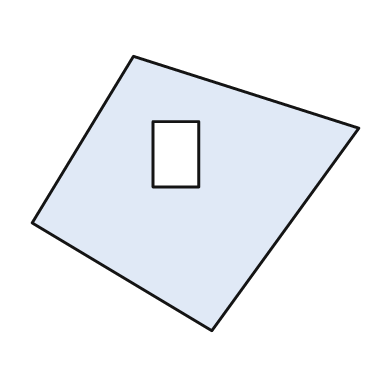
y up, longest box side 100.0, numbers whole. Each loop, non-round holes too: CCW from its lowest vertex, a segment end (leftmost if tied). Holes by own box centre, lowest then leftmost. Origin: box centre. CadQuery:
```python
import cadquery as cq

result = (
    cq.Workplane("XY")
    .moveTo(5.0, -42.0)
    .lineTo(50.0, 20.0)
    .lineTo(-19.0, 42.0)
    .lineTo(-50.0, -9.0)
    .close()
    .moveTo(-13.0, 2.0)
    .lineTo(1.0, 2.0)
    .lineTo(1.0, 22.0)
    .lineTo(-13.0, 22.0)
    .close()
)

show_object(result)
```